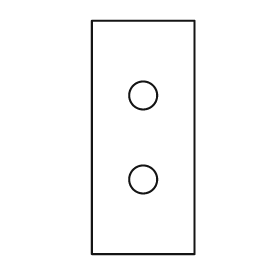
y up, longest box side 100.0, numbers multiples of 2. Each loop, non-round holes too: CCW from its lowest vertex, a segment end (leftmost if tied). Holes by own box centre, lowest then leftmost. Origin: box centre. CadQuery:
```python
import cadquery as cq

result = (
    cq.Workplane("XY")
    .moveTo(-22.0, -50.0)
    .lineTo(22.0, -50.0)
    .lineTo(22.0, 50.0)
    .lineTo(-22.0, 50.0)
    .close()
    .moveTo(0.0, -18.0)
    .circle(6.0)
    .moveTo(0.0, 18.0)
    .circle(6.0)
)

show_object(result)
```